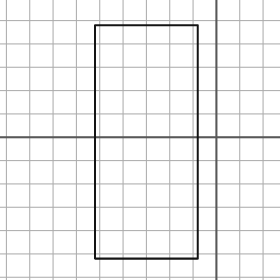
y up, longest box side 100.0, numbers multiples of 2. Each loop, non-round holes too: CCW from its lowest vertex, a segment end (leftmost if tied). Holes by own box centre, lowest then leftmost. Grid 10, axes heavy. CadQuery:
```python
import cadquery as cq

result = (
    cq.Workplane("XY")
    .moveTo(-52.0, -52.0)
    .lineTo(-8.0, -52.0)
    .lineTo(-8.0, 48.0)
    .lineTo(-52.0, 48.0)
    .close()
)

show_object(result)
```